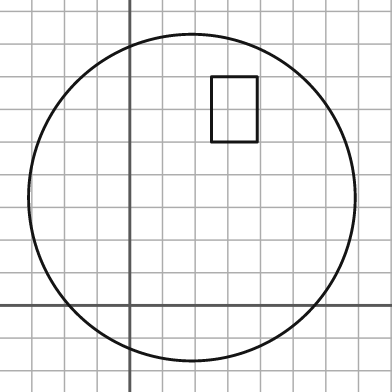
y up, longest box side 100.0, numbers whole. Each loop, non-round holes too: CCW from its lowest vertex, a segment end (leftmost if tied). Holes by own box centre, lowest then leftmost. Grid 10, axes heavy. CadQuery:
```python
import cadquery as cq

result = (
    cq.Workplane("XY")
    .moveTo(19.0, 33.0)
    .circle(50.0)
    .moveTo(25.0, 50.0)
    .lineTo(39.0, 50.0)
    .lineTo(39.0, 70.0)
    .lineTo(25.0, 70.0)
    .close()
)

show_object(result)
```